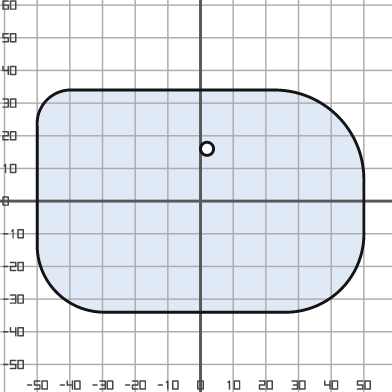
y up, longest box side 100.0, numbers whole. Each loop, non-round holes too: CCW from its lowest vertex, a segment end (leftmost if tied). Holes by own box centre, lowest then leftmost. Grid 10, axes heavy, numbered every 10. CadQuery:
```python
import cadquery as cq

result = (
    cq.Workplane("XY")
    .moveTo(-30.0, -34.0)
    .lineTo(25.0, -34.0)
    .threePointArc((43.0, -27.0), (50.0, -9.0))
    .lineTo(50.0, 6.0)
    .threePointArc((42.0, 26.0), (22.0, 34.0))
    .lineTo(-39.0, 34.0)
    .threePointArc((-47.0, 31.0), (-50.0, 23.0))
    .lineTo(-50.0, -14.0)
    .threePointArc((-44.0, -28.0), (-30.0, -34.0))
    .close()
    .moveTo(2.0, 16.0)
    .circle(2.0)
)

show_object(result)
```